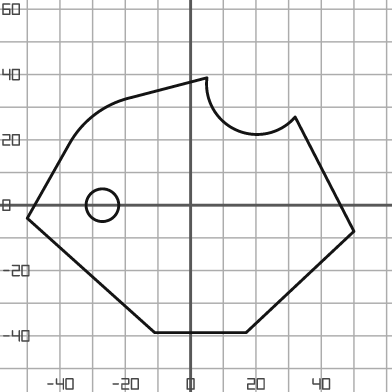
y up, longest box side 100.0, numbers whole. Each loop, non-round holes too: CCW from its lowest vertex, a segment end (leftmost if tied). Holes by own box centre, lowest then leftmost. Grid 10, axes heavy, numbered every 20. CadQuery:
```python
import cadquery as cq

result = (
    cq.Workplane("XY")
    .moveTo(-11.0, -39.0)
    .lineTo(17.0, -39.0)
    .lineTo(50.0, -8.0)
    .lineTo(32.0, 27.0)
    .threePointArc((14.0, 23.0), (5.0, 39.0))
    .lineTo(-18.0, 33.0)
    .threePointArc((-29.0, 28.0), (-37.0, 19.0))
    .lineTo(-50.0, -4.0)
    .close()
    .moveTo(-27.0, 0.0)
    .circle(5.0)
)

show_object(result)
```